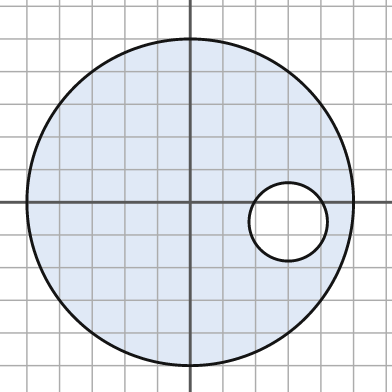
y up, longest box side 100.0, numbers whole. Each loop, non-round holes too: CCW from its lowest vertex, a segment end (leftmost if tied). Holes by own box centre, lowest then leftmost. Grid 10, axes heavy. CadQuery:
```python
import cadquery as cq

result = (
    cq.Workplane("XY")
    .moveTo(0.0, 0.0)
    .circle(50.0)
    .moveTo(30.0, -6.0)
    .circle(12.0)
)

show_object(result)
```